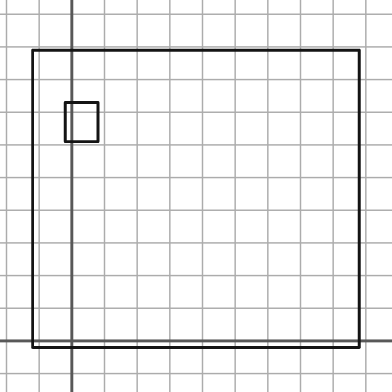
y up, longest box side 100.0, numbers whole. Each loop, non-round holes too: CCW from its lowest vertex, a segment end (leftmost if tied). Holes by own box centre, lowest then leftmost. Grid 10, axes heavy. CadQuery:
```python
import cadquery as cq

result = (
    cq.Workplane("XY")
    .moveTo(-12.0, -2.0)
    .lineTo(88.0, -2.0)
    .lineTo(88.0, 89.0)
    .lineTo(-12.0, 89.0)
    .close()
    .moveTo(-2.0, 61.0)
    .lineTo(8.0, 61.0)
    .lineTo(8.0, 73.0)
    .lineTo(-2.0, 73.0)
    .close()
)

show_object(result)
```